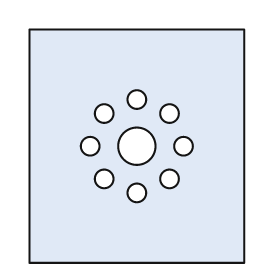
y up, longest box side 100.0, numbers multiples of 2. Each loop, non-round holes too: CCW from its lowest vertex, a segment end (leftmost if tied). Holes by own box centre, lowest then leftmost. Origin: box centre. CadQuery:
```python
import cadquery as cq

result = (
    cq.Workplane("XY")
    .moveTo(-46.0, -50.0)
    .lineTo(46.0, -50.0)
    .lineTo(46.0, 50.0)
    .lineTo(-46.0, 50.0)
    .close()
    .moveTo(0.0, -20.0)
    .circle(4.0)
    .moveTo(-14.0, -14.0)
    .circle(4.0)
    .moveTo(14.0, -14.0)
    .circle(4.0)
    .moveTo(-20.0, 0.0)
    .circle(4.0)
    .moveTo(0.0, 0.0)
    .circle(8.0)
    .moveTo(20.0, 0.0)
    .circle(4.0)
    .moveTo(-14.0, 14.0)
    .circle(4.0)
    .moveTo(14.0, 14.0)
    .circle(4.0)
    .moveTo(0.0, 20.0)
    .circle(4.0)
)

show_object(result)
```